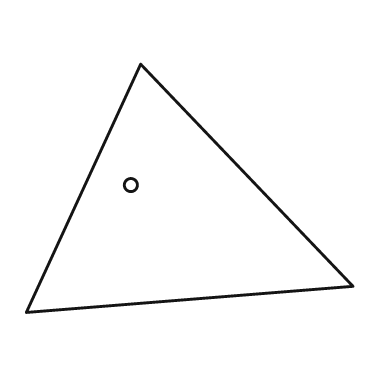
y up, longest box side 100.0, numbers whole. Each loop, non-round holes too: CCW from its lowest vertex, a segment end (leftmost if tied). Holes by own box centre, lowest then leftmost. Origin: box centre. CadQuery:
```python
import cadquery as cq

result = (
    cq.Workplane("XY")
    .moveTo(-50.0, -38.0)
    .lineTo(50.0, -30.0)
    .lineTo(-15.0, 38.0)
    .close()
    .moveTo(-18.0, 1.0)
    .circle(2.0)
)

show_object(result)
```